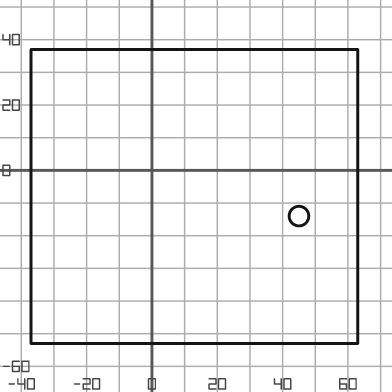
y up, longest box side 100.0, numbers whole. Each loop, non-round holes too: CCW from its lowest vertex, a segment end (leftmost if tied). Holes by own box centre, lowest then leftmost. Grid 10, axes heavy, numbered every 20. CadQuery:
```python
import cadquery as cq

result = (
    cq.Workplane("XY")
    .moveTo(-37.0, -53.0)
    .lineTo(63.0, -53.0)
    .lineTo(63.0, 37.0)
    .lineTo(-37.0, 37.0)
    .close()
    .moveTo(45.0, -14.0)
    .circle(3.0)
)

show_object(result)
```